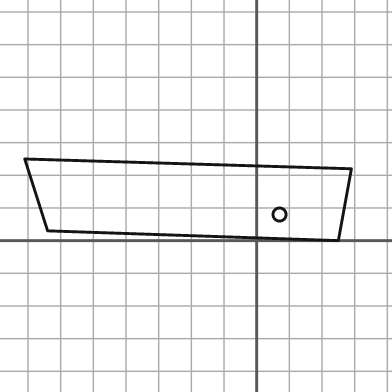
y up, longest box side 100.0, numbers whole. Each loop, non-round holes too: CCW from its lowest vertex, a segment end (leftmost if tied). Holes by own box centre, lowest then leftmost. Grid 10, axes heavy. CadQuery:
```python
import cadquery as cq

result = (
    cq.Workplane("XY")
    .moveTo(25.0, 0.0)
    .lineTo(29.0, 22.0)
    .lineTo(-71.0, 25.0)
    .lineTo(-64.0, 3.0)
    .close()
    .moveTo(7.0, 8.0)
    .circle(2.0)
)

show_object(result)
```